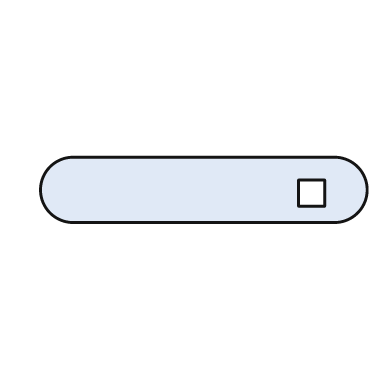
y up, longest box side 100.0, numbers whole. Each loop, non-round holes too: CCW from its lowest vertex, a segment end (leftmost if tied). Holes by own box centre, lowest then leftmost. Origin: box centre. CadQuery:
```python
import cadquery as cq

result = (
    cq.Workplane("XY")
    .moveTo(-40.0, -10.0)
    .lineTo(40.0, -10.0)
    .threePointArc((50.0, 0.0), (40.0, 10.0))
    .lineTo(-40.0, 10.0)
    .threePointArc((-50.0, 0.0), (-40.0, -10.0))
    .close()
    .moveTo(29.0, -5.0)
    .lineTo(37.0, -5.0)
    .lineTo(37.0, 3.0)
    .lineTo(29.0, 3.0)
    .close()
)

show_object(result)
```